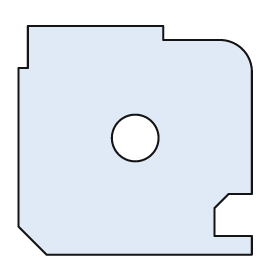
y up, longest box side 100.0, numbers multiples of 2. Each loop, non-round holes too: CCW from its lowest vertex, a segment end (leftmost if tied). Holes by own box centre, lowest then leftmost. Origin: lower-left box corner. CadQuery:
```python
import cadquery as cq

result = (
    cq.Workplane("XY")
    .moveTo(12.0, 0.0)
    .lineTo(100.0, 0.0)
    .lineTo(100.0, 8.0)
    .lineTo(84.0, 8.0)
    .lineTo(84.0, 20.0)
    .lineTo(90.0, 26.0)
    .lineTo(100.0, 26.0)
    .lineTo(100.0, 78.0)
    .threePointArc((96.0, 88.0), (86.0, 92.0))
    .lineTo(62.0, 92.0)
    .lineTo(62.0, 98.0)
    .lineTo(4.0, 98.0)
    .lineTo(4.0, 80.0)
    .lineTo(0.0, 80.0)
    .lineTo(0.0, 12.0)
    .close()
    .moveTo(50.0, 50.0)
    .circle(10.0)
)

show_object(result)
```